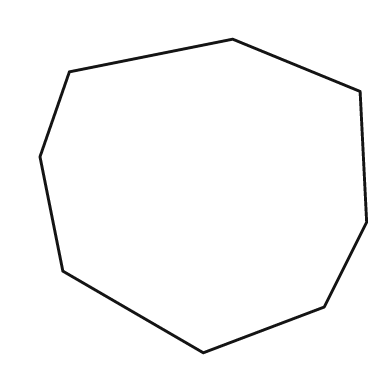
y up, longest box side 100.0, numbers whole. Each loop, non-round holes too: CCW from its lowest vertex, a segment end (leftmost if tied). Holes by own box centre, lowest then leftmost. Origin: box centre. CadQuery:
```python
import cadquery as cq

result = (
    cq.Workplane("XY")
    .moveTo(0.0, -48.0)
    .lineTo(37.0, -34.0)
    .lineTo(50.0, -8.0)
    .lineTo(48.0, 32.0)
    .lineTo(9.0, 48.0)
    .lineTo(-41.0, 38.0)
    .lineTo(-50.0, 12.0)
    .lineTo(-43.0, -23.0)
    .close()
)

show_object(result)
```